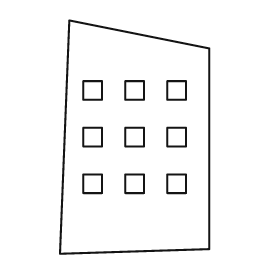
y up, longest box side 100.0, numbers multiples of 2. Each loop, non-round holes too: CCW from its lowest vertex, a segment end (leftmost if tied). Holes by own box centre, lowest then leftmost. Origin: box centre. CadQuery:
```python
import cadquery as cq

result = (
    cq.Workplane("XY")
    .moveTo(-32.0, -50.0)
    .lineTo(32.0, -48.0)
    .lineTo(32.0, 38.0)
    .lineTo(-28.0, 50.0)
    .close()
    .moveTo(-22.0, -24.0)
    .lineTo(-14.0, -24.0)
    .lineTo(-14.0, -16.0)
    .lineTo(-22.0, -16.0)
    .close()
    .moveTo(-4.0, -24.0)
    .lineTo(4.0, -24.0)
    .lineTo(4.0, -16.0)
    .lineTo(-4.0, -16.0)
    .close()
    .moveTo(14.0, -24.0)
    .lineTo(22.0, -24.0)
    .lineTo(22.0, -16.0)
    .lineTo(14.0, -16.0)
    .close()
    .moveTo(-22.0, -4.0)
    .lineTo(-14.0, -4.0)
    .lineTo(-14.0, 4.0)
    .lineTo(-22.0, 4.0)
    .close()
    .moveTo(-4.0, -4.0)
    .lineTo(4.0, -4.0)
    .lineTo(4.0, 4.0)
    .lineTo(-4.0, 4.0)
    .close()
    .moveTo(14.0, -4.0)
    .lineTo(22.0, -4.0)
    .lineTo(22.0, 4.0)
    .lineTo(14.0, 4.0)
    .close()
    .moveTo(-22.0, 16.0)
    .lineTo(-14.0, 16.0)
    .lineTo(-14.0, 24.0)
    .lineTo(-22.0, 24.0)
    .close()
    .moveTo(-4.0, 16.0)
    .lineTo(4.0, 16.0)
    .lineTo(4.0, 24.0)
    .lineTo(-4.0, 24.0)
    .close()
    .moveTo(14.0, 16.0)
    .lineTo(22.0, 16.0)
    .lineTo(22.0, 24.0)
    .lineTo(14.0, 24.0)
    .close()
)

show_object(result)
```